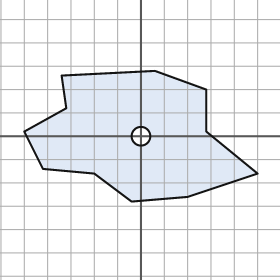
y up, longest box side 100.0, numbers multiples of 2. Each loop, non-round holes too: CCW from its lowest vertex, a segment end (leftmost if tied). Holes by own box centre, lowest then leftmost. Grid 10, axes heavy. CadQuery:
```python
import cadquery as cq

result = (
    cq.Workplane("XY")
    .moveTo(-4.0, -28.0)
    .lineTo(20.0, -26.0)
    .lineTo(50.0, -16.0)
    .lineTo(28.0, 2.0)
    .lineTo(28.0, 20.0)
    .lineTo(6.0, 28.0)
    .lineTo(-34.0, 26.0)
    .lineTo(-32.0, 12.0)
    .lineTo(-50.0, 2.0)
    .lineTo(-42.0, -14.0)
    .lineTo(-20.0, -16.0)
    .close()
    .moveTo(0.0, 0.0)
    .circle(4.0)
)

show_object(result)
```